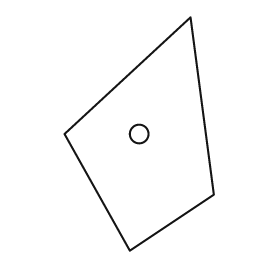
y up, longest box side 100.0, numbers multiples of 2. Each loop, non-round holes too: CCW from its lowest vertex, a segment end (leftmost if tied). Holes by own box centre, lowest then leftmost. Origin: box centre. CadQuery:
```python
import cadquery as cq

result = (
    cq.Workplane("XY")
    .moveTo(-4.0, -50.0)
    .lineTo(32.0, -26.0)
    .lineTo(22.0, 50.0)
    .lineTo(-32.0, 0.0)
    .close()
    .moveTo(0.0, 0.0)
    .circle(4.0)
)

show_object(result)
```